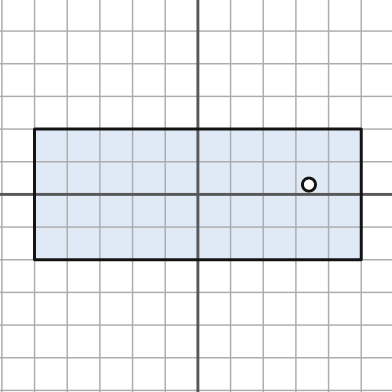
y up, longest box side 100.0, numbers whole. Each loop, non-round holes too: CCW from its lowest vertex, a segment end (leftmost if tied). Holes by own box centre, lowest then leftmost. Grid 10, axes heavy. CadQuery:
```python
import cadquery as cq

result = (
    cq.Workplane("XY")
    .moveTo(-50.0, -20.0)
    .lineTo(50.0, -20.0)
    .lineTo(50.0, 20.0)
    .lineTo(-50.0, 20.0)
    .close()
    .moveTo(34.0, 3.0)
    .circle(2.0)
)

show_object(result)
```